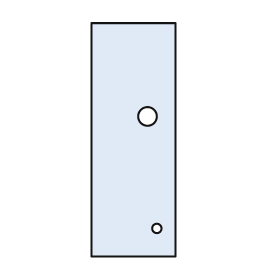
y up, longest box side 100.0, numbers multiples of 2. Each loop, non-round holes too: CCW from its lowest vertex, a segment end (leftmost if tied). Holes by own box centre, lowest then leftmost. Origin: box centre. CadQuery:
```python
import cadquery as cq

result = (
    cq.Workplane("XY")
    .moveTo(-18.0, -50.0)
    .lineTo(18.0, -50.0)
    .lineTo(18.0, 50.0)
    .lineTo(-18.0, 50.0)
    .close()
    .moveTo(10.0, -38.0)
    .circle(2.0)
    .moveTo(6.0, 10.0)
    .circle(4.0)
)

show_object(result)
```